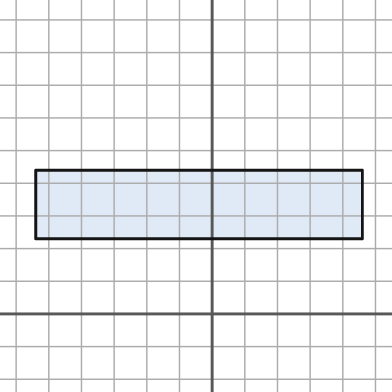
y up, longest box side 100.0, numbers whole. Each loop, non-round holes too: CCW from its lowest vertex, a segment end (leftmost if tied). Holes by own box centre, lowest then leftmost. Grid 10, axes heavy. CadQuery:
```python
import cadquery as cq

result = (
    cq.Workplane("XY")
    .moveTo(-54.0, 23.0)
    .lineTo(46.0, 23.0)
    .lineTo(46.0, 44.0)
    .lineTo(-54.0, 44.0)
    .close()
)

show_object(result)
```